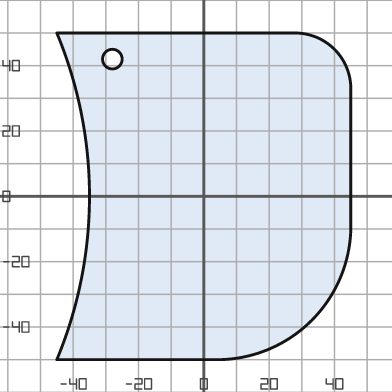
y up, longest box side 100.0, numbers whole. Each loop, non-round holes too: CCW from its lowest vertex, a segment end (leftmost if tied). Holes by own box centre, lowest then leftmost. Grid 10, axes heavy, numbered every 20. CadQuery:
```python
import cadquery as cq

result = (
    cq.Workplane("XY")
    .moveTo(-45.0, -50.0)
    .lineTo(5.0, -50.0)
    .threePointArc((33.0, -38.0), (45.0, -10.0))
    .lineTo(45.0, 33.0)
    .threePointArc((40.0, 45.0), (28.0, 50.0))
    .lineTo(-45.0, 50.0)
    .threePointArc((-35.0, 0.0), (-45.0, -50.0))
    .close()
    .moveTo(-28.0, 42.0)
    .circle(3.0)
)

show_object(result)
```